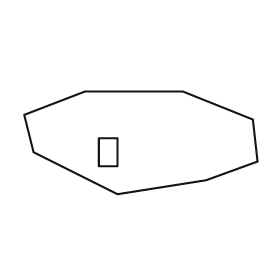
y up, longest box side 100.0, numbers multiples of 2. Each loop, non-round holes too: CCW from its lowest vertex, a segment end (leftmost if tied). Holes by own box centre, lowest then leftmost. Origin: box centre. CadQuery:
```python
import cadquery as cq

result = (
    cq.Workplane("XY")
    .moveTo(-10.0, -22.0)
    .lineTo(28.0, -16.0)
    .lineTo(50.0, -8.0)
    .lineTo(48.0, 10.0)
    .lineTo(18.0, 22.0)
    .lineTo(-24.0, 22.0)
    .lineTo(-50.0, 12.0)
    .lineTo(-46.0, -4.0)
    .close()
    .moveTo(-18.0, -10.0)
    .lineTo(-10.0, -10.0)
    .lineTo(-10.0, 2.0)
    .lineTo(-18.0, 2.0)
    .close()
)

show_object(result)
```